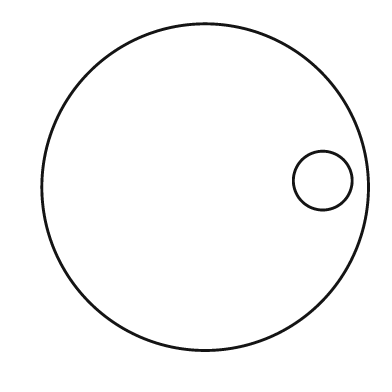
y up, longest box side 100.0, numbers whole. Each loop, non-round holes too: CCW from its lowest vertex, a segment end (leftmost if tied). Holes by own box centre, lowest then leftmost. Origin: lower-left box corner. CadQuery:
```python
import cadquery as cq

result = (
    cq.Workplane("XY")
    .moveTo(50.0, 50.0)
    .circle(50.0)
    .moveTo(86.0, 52.0)
    .circle(9.0)
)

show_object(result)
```